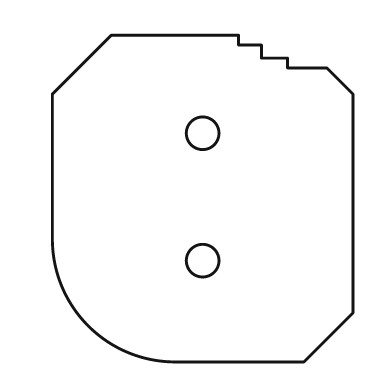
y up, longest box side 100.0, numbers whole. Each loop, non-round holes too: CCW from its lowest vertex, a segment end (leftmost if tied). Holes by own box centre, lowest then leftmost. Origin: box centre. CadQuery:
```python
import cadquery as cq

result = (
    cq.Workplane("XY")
    .moveTo(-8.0, -50.0)
    .lineTo(31.0, -50.0)
    .lineTo(46.0, -35.0)
    .lineTo(46.0, 32.0)
    .lineTo(38.0, 40.0)
    .lineTo(26.0, 40.0)
    .lineTo(26.0, 43.0)
    .lineTo(18.0, 43.0)
    .lineTo(18.0, 47.0)
    .lineTo(11.0, 47.0)
    .lineTo(11.0, 50.0)
    .lineTo(-28.0, 50.0)
    .lineTo(-46.0, 32.0)
    .lineTo(-46.0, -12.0)
    .threePointArc((-35.0, -39.0), (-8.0, -50.0))
    .close()
    .moveTo(0.0, -19.0)
    .circle(5.0)
    .moveTo(0.0, 20.0)
    .circle(5.0)
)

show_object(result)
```